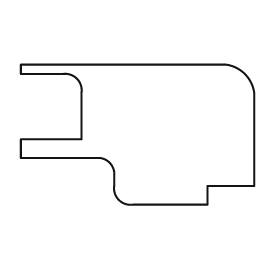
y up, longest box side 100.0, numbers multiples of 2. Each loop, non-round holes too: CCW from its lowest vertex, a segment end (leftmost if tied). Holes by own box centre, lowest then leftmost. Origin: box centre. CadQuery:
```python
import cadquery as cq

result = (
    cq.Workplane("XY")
    .moveTo(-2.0, -30.0)
    .lineTo(30.0, -30.0)
    .lineTo(30.0, -22.0)
    .lineTo(50.0, -22.0)
    .lineTo(50.0, 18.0)
    .threePointArc((46.0, 26.0), (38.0, 30.0))
    .lineTo(-50.0, 30.0)
    .lineTo(-50.0, 26.0)
    .lineTo(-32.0, 26.0)
    .threePointArc((-26.0, 24.0), (-24.0, 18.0))
    .lineTo(-24.0, -2.0)
    .lineTo(-50.0, -2.0)
    .lineTo(-50.0, -10.0)
    .lineTo(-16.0, -10.0)
    .threePointArc((-12.0, -12.0), (-10.0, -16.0))
    .lineTo(-10.0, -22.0)
    .threePointArc((-8.0, -28.0), (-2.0, -30.0))
    .close()
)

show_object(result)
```